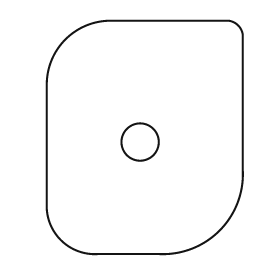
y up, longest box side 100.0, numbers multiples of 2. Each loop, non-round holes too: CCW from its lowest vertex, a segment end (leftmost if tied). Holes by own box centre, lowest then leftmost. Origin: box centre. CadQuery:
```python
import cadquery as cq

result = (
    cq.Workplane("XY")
    .moveTo(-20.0, -50.0)
    .lineTo(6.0, -50.0)
    .threePointArc((32.0, -40.0), (42.0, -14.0))
    .lineTo(42.0, 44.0)
    .threePointArc((40.0, 48.0), (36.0, 50.0))
    .lineTo(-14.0, 50.0)
    .threePointArc((-34.0, 42.0), (-42.0, 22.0))
    .lineTo(-42.0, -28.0)
    .threePointArc((-36.0, -44.0), (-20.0, -50.0))
    .close()
    .moveTo(-2.0, -2.0)
    .circle(8.0)
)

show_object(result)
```